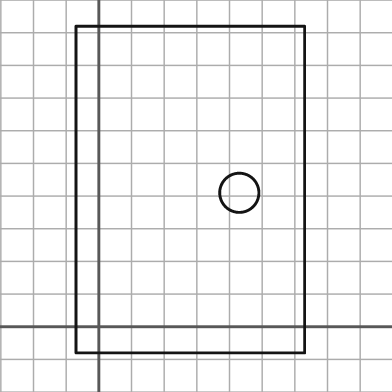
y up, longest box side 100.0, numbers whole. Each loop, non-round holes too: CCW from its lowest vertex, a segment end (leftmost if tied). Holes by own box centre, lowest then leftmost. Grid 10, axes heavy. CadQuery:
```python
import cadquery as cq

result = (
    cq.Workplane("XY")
    .moveTo(-7.0, -8.0)
    .lineTo(63.0, -8.0)
    .lineTo(63.0, 92.0)
    .lineTo(-7.0, 92.0)
    .close()
    .moveTo(43.0, 41.0)
    .circle(6.0)
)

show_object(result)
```